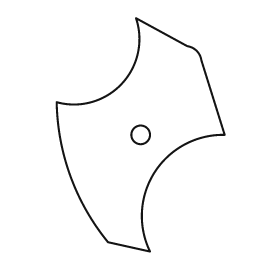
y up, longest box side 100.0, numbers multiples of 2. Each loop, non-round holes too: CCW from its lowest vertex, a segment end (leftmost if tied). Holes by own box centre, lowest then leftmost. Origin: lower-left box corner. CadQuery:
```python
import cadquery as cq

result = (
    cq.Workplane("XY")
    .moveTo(40.0, 0.0)
    .threePointArc((42.0, 34.0), (72.0, 50.0))
    .lineTo(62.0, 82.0)
    .threePointArc((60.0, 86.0), (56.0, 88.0))
    .lineTo(34.0, 100.0)
    .threePointArc((28.0, 72.0), (0.0, 64.0))
    .threePointArc((6.0, 32.0), (22.0, 4.0))
    .close()
    .moveTo(36.0, 50.0)
    .circle(4.0)
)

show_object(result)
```